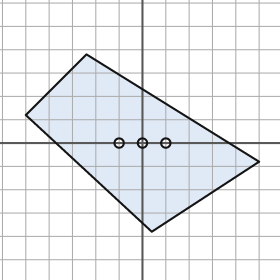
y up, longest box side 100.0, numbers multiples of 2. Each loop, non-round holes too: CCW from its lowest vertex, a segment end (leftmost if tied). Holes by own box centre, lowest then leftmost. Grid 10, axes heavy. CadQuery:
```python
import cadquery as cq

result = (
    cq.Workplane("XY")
    .moveTo(4.0, -38.0)
    .lineTo(50.0, -8.0)
    .lineTo(-24.0, 38.0)
    .lineTo(-50.0, 12.0)
    .close()
    .moveTo(-10.0, 0.0)
    .circle(2.0)
    .moveTo(0.0, 0.0)
    .circle(2.0)
    .moveTo(10.0, 0.0)
    .circle(2.0)
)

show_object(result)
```